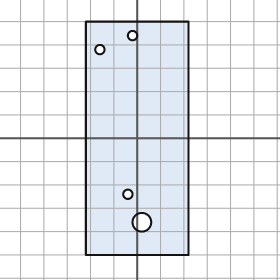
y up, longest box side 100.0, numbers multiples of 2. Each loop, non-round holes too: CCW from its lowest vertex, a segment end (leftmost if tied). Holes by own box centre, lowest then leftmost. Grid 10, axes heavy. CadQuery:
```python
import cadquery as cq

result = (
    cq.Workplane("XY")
    .moveTo(-22.0, -50.0)
    .lineTo(22.0, -50.0)
    .lineTo(22.0, 50.0)
    .lineTo(-22.0, 50.0)
    .close()
    .moveTo(2.0, -36.0)
    .circle(4.0)
    .moveTo(-4.0, -24.0)
    .circle(2.0)
    .moveTo(-16.0, 38.0)
    .circle(2.0)
    .moveTo(-2.0, 44.0)
    .circle(2.0)
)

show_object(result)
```